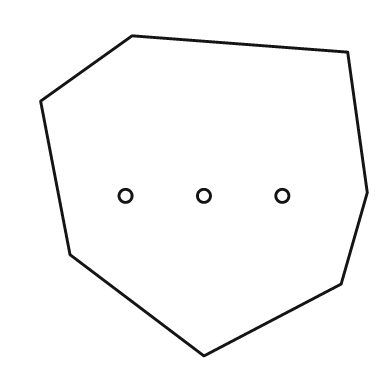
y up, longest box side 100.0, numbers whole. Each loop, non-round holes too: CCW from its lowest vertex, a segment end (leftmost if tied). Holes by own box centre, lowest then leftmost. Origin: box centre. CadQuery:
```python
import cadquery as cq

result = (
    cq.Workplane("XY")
    .moveTo(0.0, -49.0)
    .lineTo(42.0, -27.0)
    .lineTo(50.0, 1.0)
    .lineTo(44.0, 44.0)
    .lineTo(-22.0, 49.0)
    .lineTo(-50.0, 29.0)
    .lineTo(-41.0, -18.0)
    .close()
    .moveTo(-24.0, 0.0)
    .circle(2.0)
    .moveTo(0.0, 0.0)
    .circle(2.0)
    .moveTo(24.0, 0.0)
    .circle(2.0)
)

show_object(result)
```